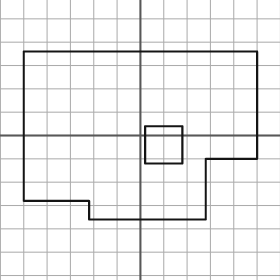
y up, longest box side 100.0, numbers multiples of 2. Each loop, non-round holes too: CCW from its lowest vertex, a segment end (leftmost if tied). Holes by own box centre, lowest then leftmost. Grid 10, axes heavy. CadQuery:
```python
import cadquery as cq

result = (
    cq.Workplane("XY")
    .moveTo(-22.0, -36.0)
    .lineTo(28.0, -36.0)
    .lineTo(28.0, -10.0)
    .lineTo(50.0, -10.0)
    .lineTo(50.0, 36.0)
    .lineTo(-50.0, 36.0)
    .lineTo(-50.0, -28.0)
    .lineTo(-22.0, -28.0)
    .close()
    .moveTo(2.0, -12.0)
    .lineTo(18.0, -12.0)
    .lineTo(18.0, 4.0)
    .lineTo(2.0, 4.0)
    .close()
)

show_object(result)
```